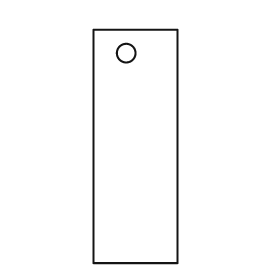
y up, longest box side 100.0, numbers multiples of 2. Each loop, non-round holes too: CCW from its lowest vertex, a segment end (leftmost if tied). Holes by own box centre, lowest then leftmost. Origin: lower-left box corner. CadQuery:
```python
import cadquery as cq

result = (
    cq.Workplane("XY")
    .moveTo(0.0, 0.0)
    .lineTo(36.0, 0.0)
    .lineTo(36.0, 100.0)
    .lineTo(0.0, 100.0)
    .close()
    .moveTo(14.0, 90.0)
    .circle(4.0)
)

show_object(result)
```